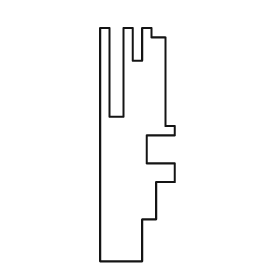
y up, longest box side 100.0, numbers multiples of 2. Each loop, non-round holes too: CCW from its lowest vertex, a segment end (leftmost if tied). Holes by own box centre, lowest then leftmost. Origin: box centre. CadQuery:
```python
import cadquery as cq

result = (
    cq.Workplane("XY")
    .moveTo(-16.0, -50.0)
    .lineTo(2.0, -50.0)
    .lineTo(2.0, -32.0)
    .lineTo(8.0, -32.0)
    .lineTo(8.0, -16.0)
    .lineTo(16.0, -16.0)
    .lineTo(16.0, -8.0)
    .lineTo(4.0, -8.0)
    .lineTo(4.0, 4.0)
    .lineTo(16.0, 4.0)
    .lineTo(16.0, 8.0)
    .lineTo(12.0, 8.0)
    .lineTo(12.0, 46.0)
    .lineTo(6.0, 46.0)
    .lineTo(6.0, 50.0)
    .lineTo(2.0, 50.0)
    .lineTo(2.0, 36.0)
    .lineTo(-2.0, 36.0)
    .lineTo(-2.0, 50.0)
    .lineTo(-6.0, 50.0)
    .lineTo(-6.0, 12.0)
    .lineTo(-12.0, 12.0)
    .lineTo(-12.0, 50.0)
    .lineTo(-16.0, 50.0)
    .close()
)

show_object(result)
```